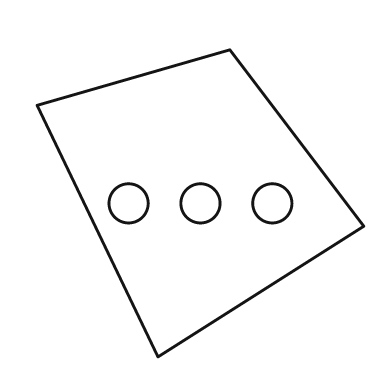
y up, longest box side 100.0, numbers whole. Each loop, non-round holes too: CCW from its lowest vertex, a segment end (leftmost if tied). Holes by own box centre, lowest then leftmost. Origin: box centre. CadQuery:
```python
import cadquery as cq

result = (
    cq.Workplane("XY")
    .moveTo(-13.0, -47.0)
    .lineTo(50.0, -7.0)
    .lineTo(9.0, 47.0)
    .lineTo(-50.0, 30.0)
    .close()
    .moveTo(-22.0, 0.0)
    .circle(6.0)
    .moveTo(0.0, 0.0)
    .circle(6.0)
    .moveTo(22.0, 0.0)
    .circle(6.0)
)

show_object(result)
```